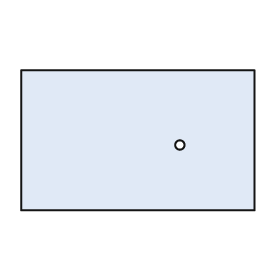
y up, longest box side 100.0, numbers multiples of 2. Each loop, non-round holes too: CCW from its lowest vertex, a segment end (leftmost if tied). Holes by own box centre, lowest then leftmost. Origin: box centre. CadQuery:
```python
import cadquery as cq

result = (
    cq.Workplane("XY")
    .moveTo(-50.0, -30.0)
    .lineTo(50.0, -30.0)
    .lineTo(50.0, 30.0)
    .lineTo(-50.0, 30.0)
    .close()
    .moveTo(18.0, -2.0)
    .circle(2.0)
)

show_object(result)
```